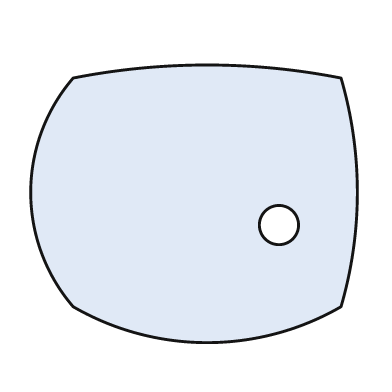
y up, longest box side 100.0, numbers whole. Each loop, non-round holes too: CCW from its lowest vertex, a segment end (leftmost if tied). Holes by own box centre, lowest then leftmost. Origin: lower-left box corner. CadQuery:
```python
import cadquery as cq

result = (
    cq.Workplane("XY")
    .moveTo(13.0, 11.0)
    .threePointArc((54.0, 0.0), (95.0, 11.0))
    .threePointArc((100.0, 46.0), (95.0, 81.0))
    .threePointArc((54.0, 85.0), (13.0, 81.0))
    .threePointArc((0.0, 46.0), (13.0, 11.0))
    .close()
    .moveTo(76.0, 36.0)
    .circle(6.0)
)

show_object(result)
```